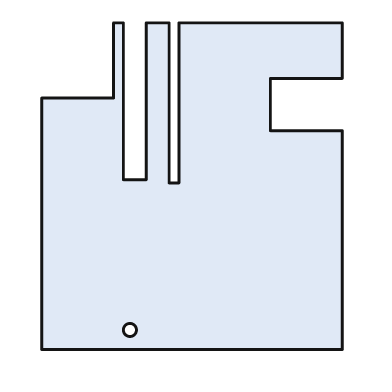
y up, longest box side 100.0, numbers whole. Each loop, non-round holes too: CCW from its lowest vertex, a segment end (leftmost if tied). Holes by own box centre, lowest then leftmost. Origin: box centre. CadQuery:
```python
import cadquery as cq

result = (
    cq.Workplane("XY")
    .moveTo(-46.0, -50.0)
    .lineTo(46.0, -50.0)
    .lineTo(46.0, 17.0)
    .lineTo(24.0, 17.0)
    .lineTo(24.0, 33.0)
    .lineTo(46.0, 33.0)
    .lineTo(46.0, 50.0)
    .lineTo(-4.0, 50.0)
    .lineTo(-4.0, 1.0)
    .lineTo(-7.0, 1.0)
    .lineTo(-7.0, 50.0)
    .lineTo(-14.0, 50.0)
    .lineTo(-14.0, 2.0)
    .lineTo(-21.0, 2.0)
    .lineTo(-21.0, 50.0)
    .lineTo(-24.0, 50.0)
    .lineTo(-24.0, 27.0)
    .lineTo(-46.0, 27.0)
    .close()
    .moveTo(-19.0, -44.0)
    .circle(2.0)
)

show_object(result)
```